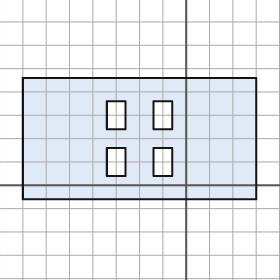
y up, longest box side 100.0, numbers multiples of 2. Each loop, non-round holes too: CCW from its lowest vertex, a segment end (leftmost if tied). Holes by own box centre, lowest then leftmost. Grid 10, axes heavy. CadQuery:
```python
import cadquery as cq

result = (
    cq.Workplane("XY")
    .moveTo(-70.0, -6.0)
    .lineTo(30.0, -6.0)
    .lineTo(30.0, 46.0)
    .lineTo(-70.0, 46.0)
    .close()
    .moveTo(-34.0, 4.0)
    .lineTo(-26.0, 4.0)
    .lineTo(-26.0, 16.0)
    .lineTo(-34.0, 16.0)
    .close()
    .moveTo(-14.0, 4.0)
    .lineTo(-6.0, 4.0)
    .lineTo(-6.0, 16.0)
    .lineTo(-14.0, 16.0)
    .close()
    .moveTo(-34.0, 24.0)
    .lineTo(-26.0, 24.0)
    .lineTo(-26.0, 36.0)
    .lineTo(-34.0, 36.0)
    .close()
    .moveTo(-14.0, 24.0)
    .lineTo(-6.0, 24.0)
    .lineTo(-6.0, 36.0)
    .lineTo(-14.0, 36.0)
    .close()
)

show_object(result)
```